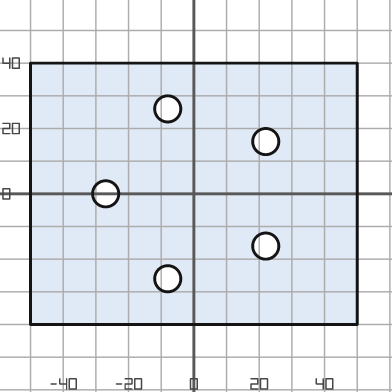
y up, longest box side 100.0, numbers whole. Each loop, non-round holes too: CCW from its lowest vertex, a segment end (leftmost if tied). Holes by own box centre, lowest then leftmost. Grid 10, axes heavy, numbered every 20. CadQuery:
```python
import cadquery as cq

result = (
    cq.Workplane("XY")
    .moveTo(-50.0, -40.0)
    .lineTo(50.0, -40.0)
    .lineTo(50.0, 40.0)
    .lineTo(-50.0, 40.0)
    .close()
    .moveTo(-8.0, -26.0)
    .circle(4.0)
    .moveTo(22.0, -16.0)
    .circle(4.0)
    .moveTo(-27.0, 0.0)
    .circle(4.0)
    .moveTo(22.0, 16.0)
    .circle(4.0)
    .moveTo(-8.0, 26.0)
    .circle(4.0)
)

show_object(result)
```